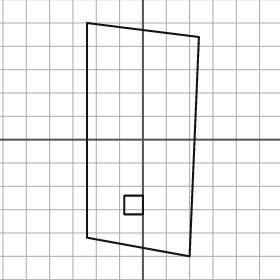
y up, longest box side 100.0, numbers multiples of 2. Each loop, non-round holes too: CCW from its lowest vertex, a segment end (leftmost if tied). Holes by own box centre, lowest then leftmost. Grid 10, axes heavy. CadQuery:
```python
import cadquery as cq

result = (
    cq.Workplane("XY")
    .moveTo(20.0, -50.0)
    .lineTo(24.0, 44.0)
    .lineTo(-24.0, 50.0)
    .lineTo(-24.0, -42.0)
    .close()
    .moveTo(-8.0, -32.0)
    .lineTo(0.0, -32.0)
    .lineTo(0.0, -24.0)
    .lineTo(-8.0, -24.0)
    .close()
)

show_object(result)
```